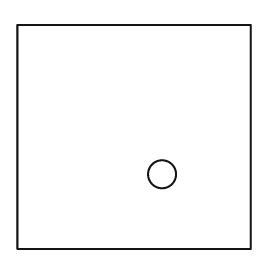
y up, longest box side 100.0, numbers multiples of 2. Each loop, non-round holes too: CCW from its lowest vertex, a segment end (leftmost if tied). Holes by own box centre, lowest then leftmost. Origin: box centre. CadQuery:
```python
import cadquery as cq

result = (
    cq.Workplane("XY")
    .moveTo(-50.0, -48.0)
    .lineTo(50.0, -48.0)
    .lineTo(50.0, 48.0)
    .lineTo(-50.0, 48.0)
    .close()
    .moveTo(12.0, -16.0)
    .circle(6.0)
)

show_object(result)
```